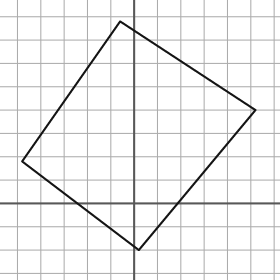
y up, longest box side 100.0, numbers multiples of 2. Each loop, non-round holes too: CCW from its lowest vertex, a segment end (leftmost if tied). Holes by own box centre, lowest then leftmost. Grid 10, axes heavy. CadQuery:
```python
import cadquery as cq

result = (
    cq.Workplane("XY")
    .moveTo(2.0, -20.0)
    .lineTo(52.0, 40.0)
    .lineTo(-6.0, 78.0)
    .lineTo(-48.0, 18.0)
    .close()
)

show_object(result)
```